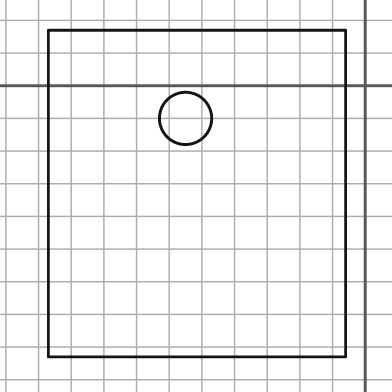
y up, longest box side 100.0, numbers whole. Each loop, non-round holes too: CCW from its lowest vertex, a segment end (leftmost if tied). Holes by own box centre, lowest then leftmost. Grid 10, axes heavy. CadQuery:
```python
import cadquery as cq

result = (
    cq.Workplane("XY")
    .moveTo(-97.0, -83.0)
    .lineTo(-6.0, -83.0)
    .lineTo(-6.0, 17.0)
    .lineTo(-97.0, 17.0)
    .close()
    .moveTo(-55.0, -10.0)
    .circle(8.0)
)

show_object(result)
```